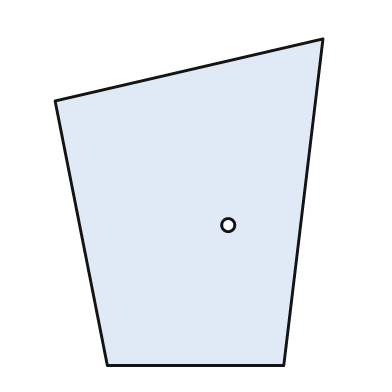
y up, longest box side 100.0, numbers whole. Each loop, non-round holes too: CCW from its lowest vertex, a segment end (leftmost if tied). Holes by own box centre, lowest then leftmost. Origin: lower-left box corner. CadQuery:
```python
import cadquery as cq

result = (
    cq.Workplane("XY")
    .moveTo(16.0, 0.0)
    .lineTo(70.0, 0.0)
    .lineTo(82.0, 100.0)
    .lineTo(0.0, 81.0)
    .close()
    .moveTo(53.0, 43.0)
    .circle(2.0)
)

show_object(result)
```